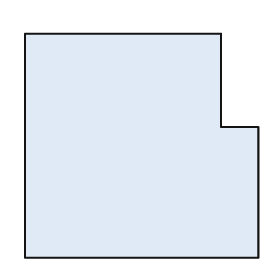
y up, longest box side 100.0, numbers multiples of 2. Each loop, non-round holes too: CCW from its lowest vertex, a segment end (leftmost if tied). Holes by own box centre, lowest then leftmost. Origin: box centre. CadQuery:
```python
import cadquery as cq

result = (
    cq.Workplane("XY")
    .moveTo(-50.0, -48.0)
    .lineTo(50.0, -48.0)
    .lineTo(50.0, 8.0)
    .lineTo(34.0, 8.0)
    .lineTo(34.0, 48.0)
    .lineTo(-50.0, 48.0)
    .close()
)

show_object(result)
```